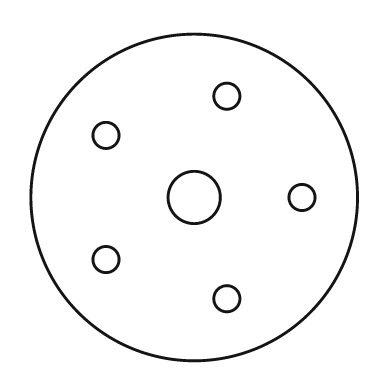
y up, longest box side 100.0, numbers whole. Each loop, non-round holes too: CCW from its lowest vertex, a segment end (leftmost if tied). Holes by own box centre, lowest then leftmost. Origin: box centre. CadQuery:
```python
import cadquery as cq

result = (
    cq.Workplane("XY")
    .moveTo(0.0, 0.0)
    .circle(50.0)
    .moveTo(10.0, -31.0)
    .circle(4.0)
    .moveTo(-27.0, -19.0)
    .circle(4.0)
    .moveTo(0.0, 0.0)
    .circle(8.0)
    .moveTo(33.0, 0.0)
    .circle(4.0)
    .moveTo(-27.0, 19.0)
    .circle(4.0)
    .moveTo(10.0, 31.0)
    .circle(4.0)
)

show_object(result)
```